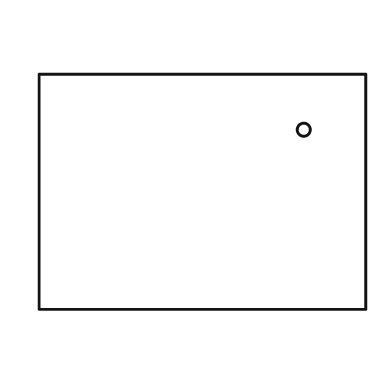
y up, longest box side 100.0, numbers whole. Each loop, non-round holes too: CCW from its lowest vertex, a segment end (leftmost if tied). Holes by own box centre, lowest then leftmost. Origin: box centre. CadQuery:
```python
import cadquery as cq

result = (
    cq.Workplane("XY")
    .moveTo(-50.0, -36.0)
    .lineTo(50.0, -36.0)
    .lineTo(50.0, 36.0)
    .lineTo(-50.0, 36.0)
    .close()
    .moveTo(31.0, 19.0)
    .circle(2.0)
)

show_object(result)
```